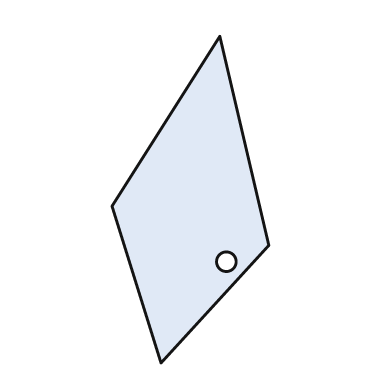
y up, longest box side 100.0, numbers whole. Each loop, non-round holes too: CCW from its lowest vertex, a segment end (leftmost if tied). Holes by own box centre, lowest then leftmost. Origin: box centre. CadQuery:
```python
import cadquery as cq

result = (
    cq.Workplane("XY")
    .moveTo(-9.0, -50.0)
    .lineTo(24.0, -14.0)
    .lineTo(9.0, 50.0)
    .lineTo(-24.0, -2.0)
    .close()
    .moveTo(11.0, -19.0)
    .circle(3.0)
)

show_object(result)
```